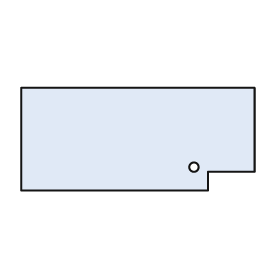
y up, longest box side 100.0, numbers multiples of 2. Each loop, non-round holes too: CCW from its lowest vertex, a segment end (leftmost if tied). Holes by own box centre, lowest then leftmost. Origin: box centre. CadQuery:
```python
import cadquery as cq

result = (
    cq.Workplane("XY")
    .moveTo(-50.0, -22.0)
    .lineTo(30.0, -22.0)
    .lineTo(30.0, -14.0)
    .lineTo(50.0, -14.0)
    .lineTo(50.0, 22.0)
    .lineTo(-50.0, 22.0)
    .close()
    .moveTo(24.0, -12.0)
    .circle(2.0)
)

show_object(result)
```